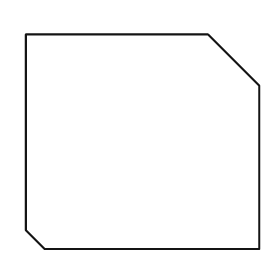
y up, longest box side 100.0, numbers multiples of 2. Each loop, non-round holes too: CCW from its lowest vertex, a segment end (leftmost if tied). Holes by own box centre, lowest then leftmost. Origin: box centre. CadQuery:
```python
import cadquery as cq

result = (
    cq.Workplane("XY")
    .moveTo(-42.0, -46.0)
    .lineTo(50.0, -46.0)
    .lineTo(50.0, 24.0)
    .lineTo(28.0, 46.0)
    .lineTo(-50.0, 46.0)
    .lineTo(-50.0, -38.0)
    .close()
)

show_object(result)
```